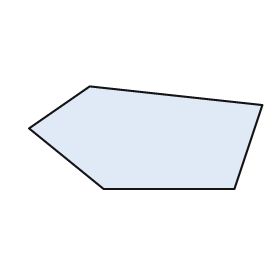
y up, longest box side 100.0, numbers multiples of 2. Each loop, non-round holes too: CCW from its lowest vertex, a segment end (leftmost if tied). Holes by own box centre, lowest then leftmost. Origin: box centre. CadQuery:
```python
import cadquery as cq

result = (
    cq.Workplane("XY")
    .moveTo(-18.0, -22.0)
    .lineTo(38.0, -22.0)
    .lineTo(50.0, 14.0)
    .lineTo(-24.0, 22.0)
    .lineTo(-50.0, 4.0)
    .close()
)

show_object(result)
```